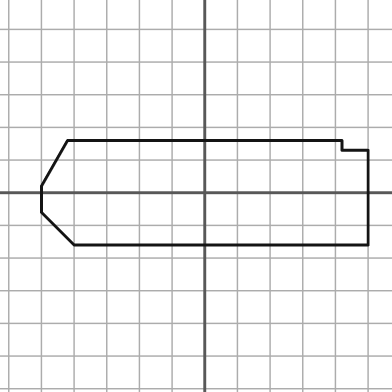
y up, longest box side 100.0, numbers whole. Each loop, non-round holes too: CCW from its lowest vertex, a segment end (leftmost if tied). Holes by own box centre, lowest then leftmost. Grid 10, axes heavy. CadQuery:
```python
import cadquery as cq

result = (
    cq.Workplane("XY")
    .moveTo(-40.0, -16.0)
    .lineTo(50.0, -16.0)
    .lineTo(50.0, 13.0)
    .lineTo(42.0, 13.0)
    .lineTo(42.0, 16.0)
    .lineTo(-42.0, 16.0)
    .lineTo(-50.0, 2.0)
    .lineTo(-50.0, -6.0)
    .close()
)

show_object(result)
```